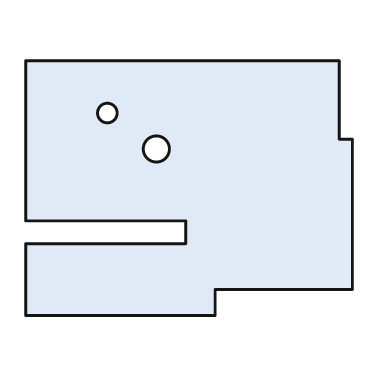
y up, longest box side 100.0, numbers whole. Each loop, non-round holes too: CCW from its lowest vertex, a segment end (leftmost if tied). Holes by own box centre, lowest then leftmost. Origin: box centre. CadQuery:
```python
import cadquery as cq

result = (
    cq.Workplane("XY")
    .moveTo(-50.0, -39.0)
    .lineTo(8.0, -39.0)
    .lineTo(8.0, -31.0)
    .lineTo(50.0, -31.0)
    .lineTo(50.0, 15.0)
    .lineTo(46.0, 15.0)
    .lineTo(46.0, 39.0)
    .lineTo(-50.0, 39.0)
    .lineTo(-50.0, -10.0)
    .lineTo(-1.0, -10.0)
    .lineTo(-1.0, -17.0)
    .lineTo(-50.0, -17.0)
    .close()
    .moveTo(-10.0, 12.0)
    .circle(4.0)
    .moveTo(-25.0, 23.0)
    .circle(3.0)
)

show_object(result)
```